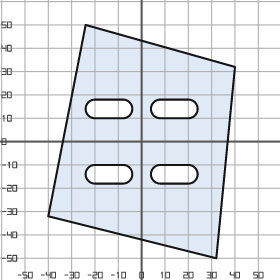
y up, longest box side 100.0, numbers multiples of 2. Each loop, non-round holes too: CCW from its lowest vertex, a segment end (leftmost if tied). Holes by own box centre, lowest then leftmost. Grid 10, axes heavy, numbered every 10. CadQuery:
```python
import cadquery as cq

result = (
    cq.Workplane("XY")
    .moveTo(32.0, -50.0)
    .lineTo(40.0, 32.0)
    .lineTo(-24.0, 50.0)
    .lineTo(-40.0, -32.0)
    .close()
    .moveTo(-20.0, -18.0)
    .lineTo(-8.0, -18.0)
    .threePointArc((-4.0, -14.0), (-8.0, -10.0))
    .lineTo(-20.0, -10.0)
    .threePointArc((-24.0, -14.0), (-20.0, -18.0))
    .close()
    .moveTo(8.0, -18.0)
    .lineTo(20.0, -18.0)
    .threePointArc((24.0, -14.0), (20.0, -10.0))
    .lineTo(8.0, -10.0)
    .threePointArc((4.0, -14.0), (8.0, -18.0))
    .close()
    .moveTo(-20.0, 10.0)
    .lineTo(-8.0, 10.0)
    .threePointArc((-4.0, 14.0), (-8.0, 18.0))
    .lineTo(-20.0, 18.0)
    .threePointArc((-24.0, 14.0), (-20.0, 10.0))
    .close()
    .moveTo(8.0, 10.0)
    .lineTo(20.0, 10.0)
    .threePointArc((24.0, 14.0), (20.0, 18.0))
    .lineTo(8.0, 18.0)
    .threePointArc((4.0, 14.0), (8.0, 10.0))
    .close()
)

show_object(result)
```